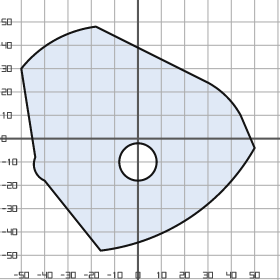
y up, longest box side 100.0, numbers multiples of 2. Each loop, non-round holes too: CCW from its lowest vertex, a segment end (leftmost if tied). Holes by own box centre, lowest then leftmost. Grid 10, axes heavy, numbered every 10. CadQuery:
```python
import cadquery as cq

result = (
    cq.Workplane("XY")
    .moveTo(-16.0, -48.0)
    .threePointArc((22.0, -34.0), (50.0, -4.0))
    .lineTo(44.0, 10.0)
    .threePointArc((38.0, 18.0), (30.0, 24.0))
    .lineTo(-18.0, 48.0)
    .threePointArc((-36.0, 42.0), (-50.0, 30.0))
    .lineTo(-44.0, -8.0)
    .threePointArc((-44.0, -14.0), (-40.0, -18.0))
    .close()
    .moveTo(0.0, -10.0)
    .circle(8.0)
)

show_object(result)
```